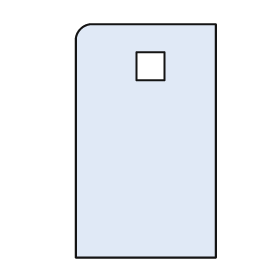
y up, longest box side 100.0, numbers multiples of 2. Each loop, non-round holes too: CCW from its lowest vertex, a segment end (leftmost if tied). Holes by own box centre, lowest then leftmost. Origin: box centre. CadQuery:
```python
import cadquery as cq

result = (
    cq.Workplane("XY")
    .moveTo(-30.0, -50.0)
    .lineTo(30.0, -50.0)
    .lineTo(30.0, 50.0)
    .lineTo(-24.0, 50.0)
    .threePointArc((-28.0, 48.0), (-30.0, 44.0))
    .close()
    .moveTo(-4.0, 26.0)
    .lineTo(8.0, 26.0)
    .lineTo(8.0, 38.0)
    .lineTo(-4.0, 38.0)
    .close()
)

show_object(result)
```